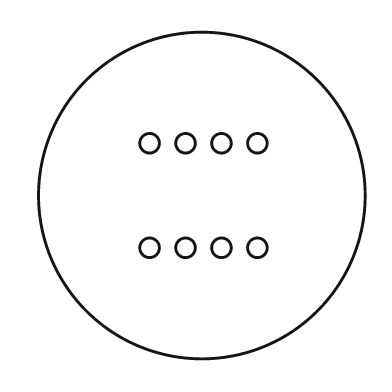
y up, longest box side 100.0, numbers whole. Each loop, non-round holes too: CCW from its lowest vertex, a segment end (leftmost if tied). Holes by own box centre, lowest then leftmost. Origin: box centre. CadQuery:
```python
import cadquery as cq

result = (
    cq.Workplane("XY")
    .moveTo(0.0, 0.0)
    .circle(50.0)
    .moveTo(-16.0, -16.0)
    .circle(3.0)
    .moveTo(-5.0, -16.0)
    .circle(3.0)
    .moveTo(6.0, -16.0)
    .circle(3.0)
    .moveTo(17.0, -16.0)
    .circle(3.0)
    .moveTo(-16.0, 16.0)
    .circle(3.0)
    .moveTo(-5.0, 16.0)
    .circle(3.0)
    .moveTo(6.0, 16.0)
    .circle(3.0)
    .moveTo(17.0, 16.0)
    .circle(3.0)
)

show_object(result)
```